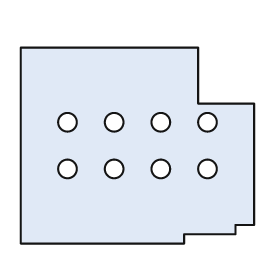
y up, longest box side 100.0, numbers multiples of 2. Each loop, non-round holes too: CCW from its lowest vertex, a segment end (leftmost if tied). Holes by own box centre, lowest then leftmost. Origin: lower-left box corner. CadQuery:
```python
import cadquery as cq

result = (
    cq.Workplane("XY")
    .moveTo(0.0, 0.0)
    .lineTo(70.0, 0.0)
    .lineTo(70.0, 4.0)
    .lineTo(92.0, 4.0)
    .lineTo(92.0, 8.0)
    .lineTo(100.0, 8.0)
    .lineTo(100.0, 60.0)
    .lineTo(76.0, 60.0)
    .lineTo(76.0, 84.0)
    .lineTo(0.0, 84.0)
    .close()
    .moveTo(20.0, 32.0)
    .circle(4.0)
    .moveTo(40.0, 32.0)
    .circle(4.0)
    .moveTo(60.0, 32.0)
    .circle(4.0)
    .moveTo(80.0, 32.0)
    .circle(4.0)
    .moveTo(20.0, 52.0)
    .circle(4.0)
    .moveTo(40.0, 52.0)
    .circle(4.0)
    .moveTo(60.0, 52.0)
    .circle(4.0)
    .moveTo(80.0, 52.0)
    .circle(4.0)
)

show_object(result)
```